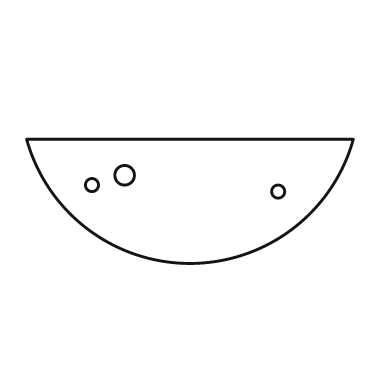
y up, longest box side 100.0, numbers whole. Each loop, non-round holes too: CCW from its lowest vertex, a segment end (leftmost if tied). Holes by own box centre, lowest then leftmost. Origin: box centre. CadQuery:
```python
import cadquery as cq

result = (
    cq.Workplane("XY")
    .moveTo(-50.0, 19.0)
    .threePointArc((0.0, -19.0), (50.0, 19.0))
    .close()
    .moveTo(27.0, 3.0)
    .circle(2.0)
    .moveTo(-30.0, 5.0)
    .circle(2.0)
    .moveTo(-20.0, 8.0)
    .circle(3.0)
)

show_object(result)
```